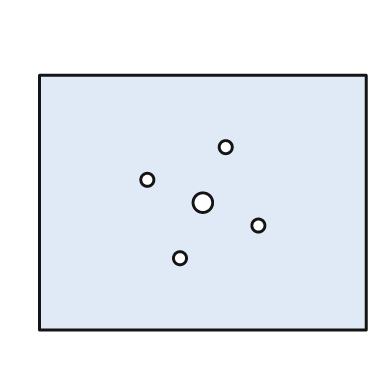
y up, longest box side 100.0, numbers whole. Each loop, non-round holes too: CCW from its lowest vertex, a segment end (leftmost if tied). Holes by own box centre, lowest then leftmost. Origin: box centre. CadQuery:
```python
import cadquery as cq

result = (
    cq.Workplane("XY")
    .moveTo(-50.0, -39.0)
    .lineTo(50.0, -39.0)
    .lineTo(50.0, 39.0)
    .lineTo(-50.0, 39.0)
    .close()
    .moveTo(-7.0, -17.0)
    .circle(2.0)
    .moveTo(17.0, -7.0)
    .circle(2.0)
    .moveTo(0.0, 0.0)
    .circle(3.0)
    .moveTo(-17.0, 7.0)
    .circle(2.0)
    .moveTo(7.0, 17.0)
    .circle(2.0)
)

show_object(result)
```